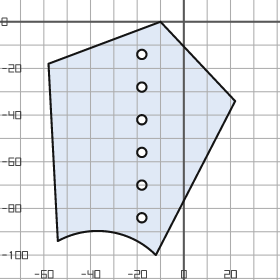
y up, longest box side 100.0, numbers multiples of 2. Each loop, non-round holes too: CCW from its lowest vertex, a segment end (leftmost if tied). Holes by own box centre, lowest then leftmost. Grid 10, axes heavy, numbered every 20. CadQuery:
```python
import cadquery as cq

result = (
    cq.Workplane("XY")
    .moveTo(-12.0, -100.0)
    .lineTo(22.0, -34.0)
    .lineTo(-10.0, 0.0)
    .lineTo(-58.0, -18.0)
    .lineTo(-54.0, -94.0)
    .threePointArc((-32.0, -90.0), (-12.0, -100.0))
    .close()
    .moveTo(-18.0, -84.0)
    .circle(2.0)
    .moveTo(-18.0, -70.0)
    .circle(2.0)
    .moveTo(-18.0, -56.0)
    .circle(2.0)
    .moveTo(-18.0, -42.0)
    .circle(2.0)
    .moveTo(-18.0, -28.0)
    .circle(2.0)
    .moveTo(-18.0, -14.0)
    .circle(2.0)
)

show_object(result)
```